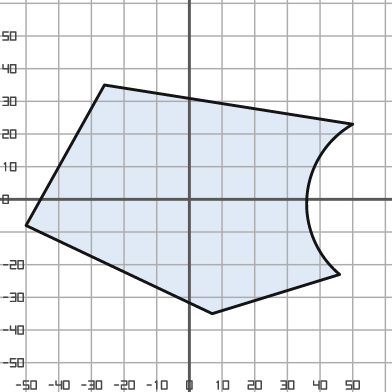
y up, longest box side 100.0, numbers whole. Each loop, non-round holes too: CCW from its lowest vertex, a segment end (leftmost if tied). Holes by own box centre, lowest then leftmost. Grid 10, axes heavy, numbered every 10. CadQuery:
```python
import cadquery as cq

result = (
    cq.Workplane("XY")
    .moveTo(7.0, -35.0)
    .lineTo(46.0, -23.0)
    .threePointArc((36.0, 1.0), (50.0, 23.0))
    .lineTo(-26.0, 35.0)
    .lineTo(-50.0, -8.0)
    .close()
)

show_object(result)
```